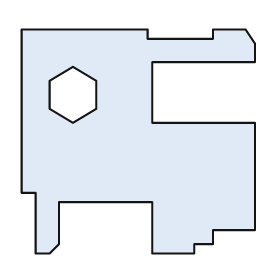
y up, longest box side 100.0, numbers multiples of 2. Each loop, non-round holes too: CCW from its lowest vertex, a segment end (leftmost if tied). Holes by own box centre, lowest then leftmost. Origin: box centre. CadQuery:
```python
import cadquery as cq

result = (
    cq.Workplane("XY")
    .moveTo(-44.0, -48.0)
    .lineTo(-38.0, -48.0)
    .lineTo(-34.0, -44.0)
    .lineTo(-34.0, -26.0)
    .lineTo(6.0, -26.0)
    .lineTo(6.0, -48.0)
    .lineTo(24.0, -48.0)
    .lineTo(24.0, -44.0)
    .lineTo(32.0, -44.0)
    .lineTo(32.0, -38.0)
    .lineTo(50.0, -38.0)
    .lineTo(50.0, 8.0)
    .lineTo(6.0, 8.0)
    .lineTo(6.0, 34.0)
    .lineTo(50.0, 34.0)
    .lineTo(50.0, 42.0)
    .lineTo(46.0, 48.0)
    .lineTo(32.0, 48.0)
    .lineTo(32.0, 44.0)
    .lineTo(4.0, 44.0)
    .lineTo(4.0, 48.0)
    .lineTo(-50.0, 48.0)
    .lineTo(-50.0, -22.0)
    .lineTo(-44.0, -22.0)
    .close()
    .moveTo(-28.0, 8.0)
    .lineTo(-18.0, 14.0)
    .lineTo(-18.0, 26.0)
    .lineTo(-28.0, 32.0)
    .lineTo(-38.0, 26.0)
    .lineTo(-38.0, 14.0)
    .close()
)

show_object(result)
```